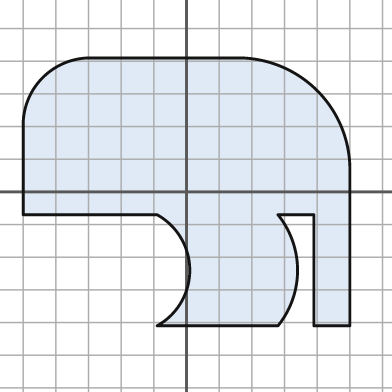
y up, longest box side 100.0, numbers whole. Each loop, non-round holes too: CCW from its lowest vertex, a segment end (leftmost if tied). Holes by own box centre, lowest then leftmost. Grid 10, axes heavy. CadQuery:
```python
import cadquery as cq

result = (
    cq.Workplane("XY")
    .moveTo(-9.0, -41.0)
    .lineTo(28.0, -41.0)
    .threePointArc((34.0, -24.0), (28.0, -7.0))
    .lineTo(39.0, -7.0)
    .lineTo(39.0, -41.0)
    .lineTo(50.0, -41.0)
    .lineTo(50.0, 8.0)
    .threePointArc((40.0, 31.0), (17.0, 41.0))
    .lineTo(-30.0, 41.0)
    .threePointArc((-44.0, 35.0), (-50.0, 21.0))
    .lineTo(-50.0, -7.0)
    .lineTo(-9.0, -7.0)
    .threePointArc((1.0, -24.0), (-9.0, -41.0))
    .close()
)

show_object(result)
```